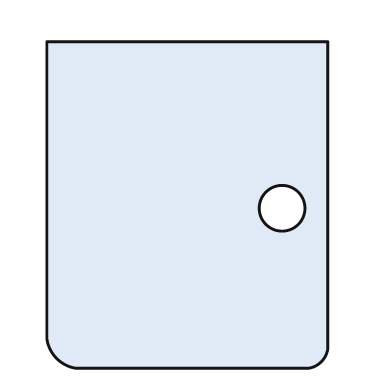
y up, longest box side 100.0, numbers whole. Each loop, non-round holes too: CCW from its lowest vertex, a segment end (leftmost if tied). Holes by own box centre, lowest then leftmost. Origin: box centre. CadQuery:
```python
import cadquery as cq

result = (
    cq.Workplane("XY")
    .moveTo(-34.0, -50.0)
    .lineTo(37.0, -50.0)
    .threePointArc((41.0, -48.0), (43.0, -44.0))
    .lineTo(43.0, 50.0)
    .lineTo(-43.0, 50.0)
    .lineTo(-43.0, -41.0)
    .threePointArc((-40.0, -47.0), (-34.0, -50.0))
    .close()
    .moveTo(29.0, -1.0)
    .circle(7.0)
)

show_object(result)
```